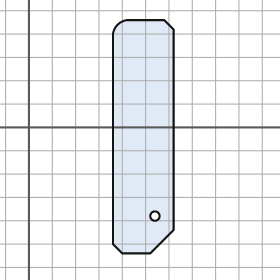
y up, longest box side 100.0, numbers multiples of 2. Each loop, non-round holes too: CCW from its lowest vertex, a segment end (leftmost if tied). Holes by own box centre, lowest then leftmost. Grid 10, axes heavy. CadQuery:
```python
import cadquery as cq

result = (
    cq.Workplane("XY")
    .moveTo(40.0, -54.0)
    .lineTo(52.0, -54.0)
    .lineTo(62.0, -44.0)
    .lineTo(62.0, 42.0)
    .lineTo(58.0, 46.0)
    .lineTo(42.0, 46.0)
    .threePointArc((38.0, 44.0), (36.0, 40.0))
    .lineTo(36.0, -50.0)
    .close()
    .moveTo(54.0, -38.0)
    .circle(2.0)
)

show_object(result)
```